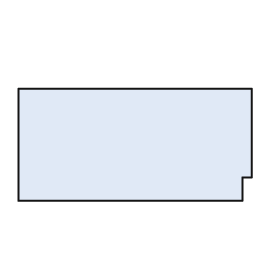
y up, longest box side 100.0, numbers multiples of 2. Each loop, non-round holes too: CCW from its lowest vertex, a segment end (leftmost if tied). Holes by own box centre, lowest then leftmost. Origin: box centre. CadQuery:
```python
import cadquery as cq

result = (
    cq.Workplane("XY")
    .moveTo(-50.0, -24.0)
    .lineTo(46.0, -24.0)
    .lineTo(46.0, -14.0)
    .lineTo(50.0, -14.0)
    .lineTo(50.0, 24.0)
    .lineTo(-50.0, 24.0)
    .close()
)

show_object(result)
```